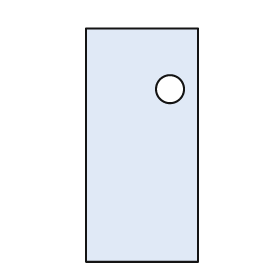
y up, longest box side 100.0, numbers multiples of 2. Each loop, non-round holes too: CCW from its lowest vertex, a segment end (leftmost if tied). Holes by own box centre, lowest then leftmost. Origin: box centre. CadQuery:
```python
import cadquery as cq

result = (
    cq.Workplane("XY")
    .moveTo(-24.0, -50.0)
    .lineTo(24.0, -50.0)
    .lineTo(24.0, 50.0)
    .lineTo(-24.0, 50.0)
    .close()
    .moveTo(12.0, 24.0)
    .circle(6.0)
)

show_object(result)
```